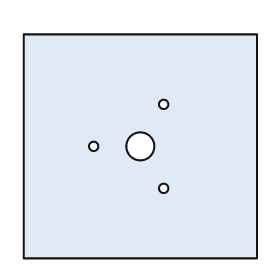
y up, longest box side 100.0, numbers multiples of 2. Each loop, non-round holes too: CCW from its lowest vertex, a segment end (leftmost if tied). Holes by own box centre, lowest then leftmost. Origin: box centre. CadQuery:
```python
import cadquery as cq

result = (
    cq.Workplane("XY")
    .moveTo(-50.0, -48.0)
    .lineTo(50.0, -48.0)
    .lineTo(50.0, 48.0)
    .lineTo(-50.0, 48.0)
    .close()
    .moveTo(10.0, -18.0)
    .circle(2.0)
    .moveTo(-20.0, 0.0)
    .circle(2.0)
    .moveTo(0.0, 0.0)
    .circle(6.0)
    .moveTo(10.0, 18.0)
    .circle(2.0)
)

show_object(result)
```